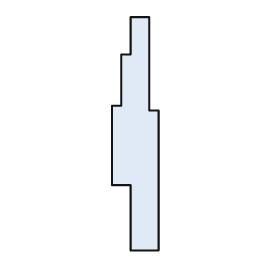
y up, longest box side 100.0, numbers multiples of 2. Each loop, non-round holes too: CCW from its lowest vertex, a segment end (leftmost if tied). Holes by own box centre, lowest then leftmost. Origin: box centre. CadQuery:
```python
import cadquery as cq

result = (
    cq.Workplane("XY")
    .moveTo(-2.0, -50.0)
    .lineTo(10.0, -50.0)
    .lineTo(10.0, 10.0)
    .lineTo(6.0, 10.0)
    .lineTo(6.0, 50.0)
    .lineTo(-2.0, 50.0)
    .lineTo(-2.0, 34.0)
    .lineTo(-6.0, 34.0)
    .lineTo(-6.0, 12.0)
    .lineTo(-10.0, 12.0)
    .lineTo(-10.0, -22.0)
    .lineTo(-2.0, -22.0)
    .close()
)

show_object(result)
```